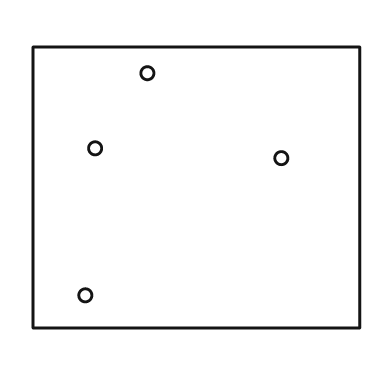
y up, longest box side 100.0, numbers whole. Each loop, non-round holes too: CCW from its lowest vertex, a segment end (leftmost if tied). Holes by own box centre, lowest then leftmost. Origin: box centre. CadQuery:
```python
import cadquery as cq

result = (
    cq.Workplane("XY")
    .moveTo(-50.0, -43.0)
    .lineTo(50.0, -43.0)
    .lineTo(50.0, 43.0)
    .lineTo(-50.0, 43.0)
    .close()
    .moveTo(-34.0, -33.0)
    .circle(2.0)
    .moveTo(26.0, 9.0)
    .circle(2.0)
    .moveTo(-31.0, 12.0)
    .circle(2.0)
    .moveTo(-15.0, 35.0)
    .circle(2.0)
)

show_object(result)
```